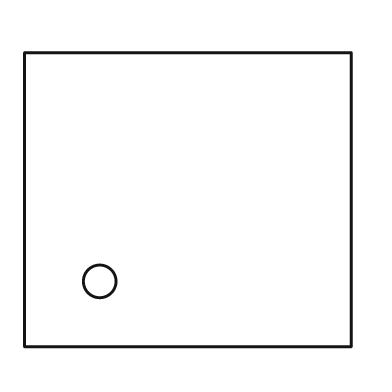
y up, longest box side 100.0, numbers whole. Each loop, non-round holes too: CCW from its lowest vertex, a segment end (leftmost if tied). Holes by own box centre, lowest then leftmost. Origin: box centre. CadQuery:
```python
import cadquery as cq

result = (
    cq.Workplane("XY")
    .moveTo(-50.0, -45.0)
    .lineTo(50.0, -45.0)
    .lineTo(50.0, 45.0)
    .lineTo(-50.0, 45.0)
    .close()
    .moveTo(-27.0, -25.0)
    .circle(5.0)
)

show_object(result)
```